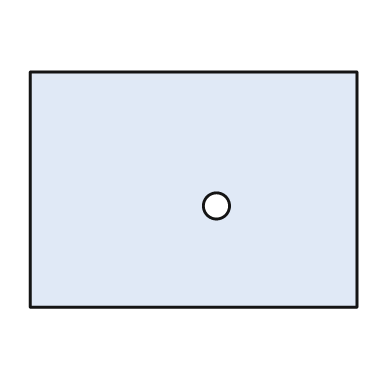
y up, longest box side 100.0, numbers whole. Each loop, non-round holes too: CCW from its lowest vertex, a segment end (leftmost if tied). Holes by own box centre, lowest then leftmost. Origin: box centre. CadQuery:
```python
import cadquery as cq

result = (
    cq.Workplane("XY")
    .moveTo(-50.0, -36.0)
    .lineTo(50.0, -36.0)
    .lineTo(50.0, 36.0)
    .lineTo(-50.0, 36.0)
    .close()
    .moveTo(7.0, -5.0)
    .circle(4.0)
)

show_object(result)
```